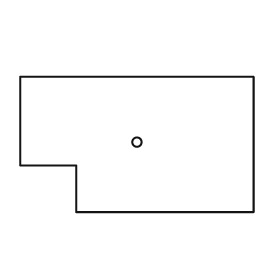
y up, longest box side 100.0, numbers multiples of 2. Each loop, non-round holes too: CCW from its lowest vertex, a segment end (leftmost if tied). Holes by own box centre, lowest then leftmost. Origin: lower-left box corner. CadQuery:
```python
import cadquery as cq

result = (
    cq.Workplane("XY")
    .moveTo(24.0, 0.0)
    .lineTo(100.0, 0.0)
    .lineTo(100.0, 58.0)
    .lineTo(0.0, 58.0)
    .lineTo(0.0, 20.0)
    .lineTo(24.0, 20.0)
    .close()
    .moveTo(50.0, 30.0)
    .circle(2.0)
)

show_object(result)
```